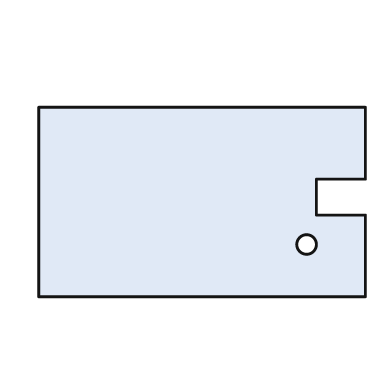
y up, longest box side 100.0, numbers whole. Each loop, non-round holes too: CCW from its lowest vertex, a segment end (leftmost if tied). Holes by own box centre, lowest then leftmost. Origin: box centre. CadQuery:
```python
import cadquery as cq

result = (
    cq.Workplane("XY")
    .moveTo(-50.0, -29.0)
    .lineTo(50.0, -29.0)
    .lineTo(50.0, -4.0)
    .lineTo(35.0, -4.0)
    .lineTo(35.0, 7.0)
    .lineTo(50.0, 7.0)
    .lineTo(50.0, 29.0)
    .lineTo(-50.0, 29.0)
    .close()
    .moveTo(32.0, -13.0)
    .circle(3.0)
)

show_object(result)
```